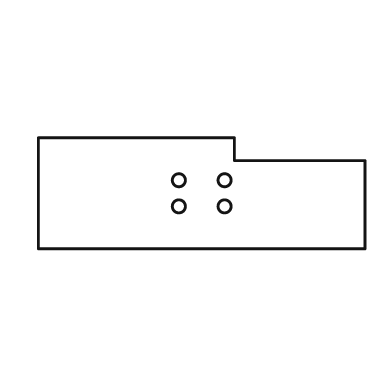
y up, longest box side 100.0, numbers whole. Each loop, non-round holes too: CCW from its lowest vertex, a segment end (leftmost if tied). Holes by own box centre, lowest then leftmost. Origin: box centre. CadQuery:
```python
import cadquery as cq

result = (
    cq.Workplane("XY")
    .moveTo(-50.0, -17.0)
    .lineTo(50.0, -17.0)
    .lineTo(50.0, 10.0)
    .lineTo(10.0, 10.0)
    .lineTo(10.0, 17.0)
    .lineTo(-50.0, 17.0)
    .close()
    .moveTo(-7.0, -4.0)
    .circle(2.0)
    .moveTo(7.0, -4.0)
    .circle(2.0)
    .moveTo(-7.0, 4.0)
    .circle(2.0)
    .moveTo(7.0, 4.0)
    .circle(2.0)
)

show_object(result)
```